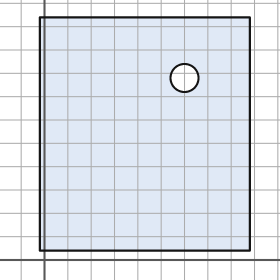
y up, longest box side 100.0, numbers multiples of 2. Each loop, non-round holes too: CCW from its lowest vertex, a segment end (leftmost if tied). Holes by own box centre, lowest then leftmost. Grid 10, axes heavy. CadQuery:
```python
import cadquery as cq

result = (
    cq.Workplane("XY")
    .moveTo(-2.0, 4.0)
    .lineTo(88.0, 4.0)
    .lineTo(88.0, 104.0)
    .lineTo(-2.0, 104.0)
    .close()
    .moveTo(60.0, 78.0)
    .circle(6.0)
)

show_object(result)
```